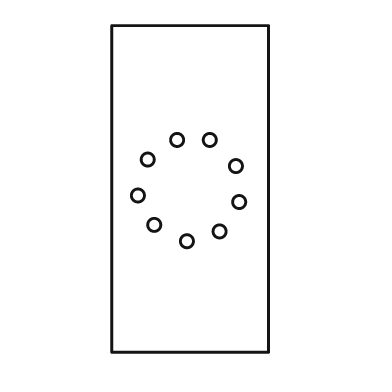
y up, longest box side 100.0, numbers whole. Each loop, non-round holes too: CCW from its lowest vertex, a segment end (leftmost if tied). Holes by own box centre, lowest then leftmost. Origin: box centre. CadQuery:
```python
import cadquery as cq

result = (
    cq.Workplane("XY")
    .moveTo(-24.0, -50.0)
    .lineTo(24.0, -50.0)
    .lineTo(24.0, 50.0)
    .lineTo(-24.0, 50.0)
    .close()
    .moveTo(-1.0, -16.0)
    .circle(2.0)
    .moveTo(9.0, -13.0)
    .circle(2.0)
    .moveTo(-11.0, -11.0)
    .circle(2.0)
    .moveTo(15.0, -4.0)
    .circle(2.0)
    .moveTo(-16.0, -2.0)
    .circle(2.0)
    .moveTo(14.0, 7.0)
    .circle(2.0)
    .moveTo(-13.0, 9.0)
    .circle(2.0)
    .moveTo(-4.0, 15.0)
    .circle(2.0)
    .moveTo(6.0, 15.0)
    .circle(2.0)
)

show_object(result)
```